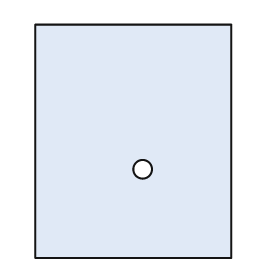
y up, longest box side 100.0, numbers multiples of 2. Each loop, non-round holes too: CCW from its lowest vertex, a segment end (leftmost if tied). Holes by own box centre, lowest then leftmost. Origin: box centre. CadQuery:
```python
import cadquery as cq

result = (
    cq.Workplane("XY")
    .moveTo(-42.0, -50.0)
    .lineTo(42.0, -50.0)
    .lineTo(42.0, 50.0)
    .lineTo(-42.0, 50.0)
    .close()
    .moveTo(4.0, -12.0)
    .circle(4.0)
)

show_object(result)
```